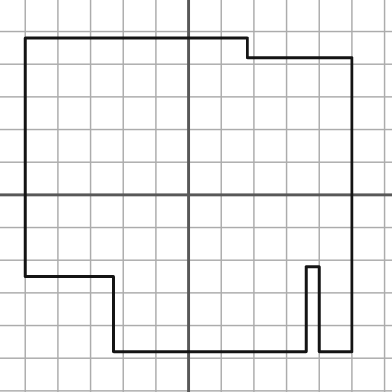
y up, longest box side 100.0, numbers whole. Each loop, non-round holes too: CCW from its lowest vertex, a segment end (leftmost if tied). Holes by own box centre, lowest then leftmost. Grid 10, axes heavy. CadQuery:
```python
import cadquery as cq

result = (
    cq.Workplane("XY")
    .moveTo(-23.0, -48.0)
    .lineTo(36.0, -48.0)
    .lineTo(36.0, -22.0)
    .lineTo(40.0, -22.0)
    .lineTo(40.0, -48.0)
    .lineTo(50.0, -48.0)
    .lineTo(50.0, 42.0)
    .lineTo(18.0, 42.0)
    .lineTo(18.0, 48.0)
    .lineTo(-50.0, 48.0)
    .lineTo(-50.0, -25.0)
    .lineTo(-23.0, -25.0)
    .close()
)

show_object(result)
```